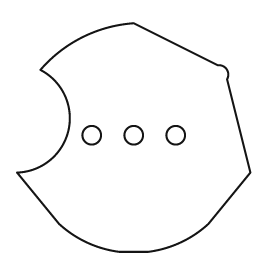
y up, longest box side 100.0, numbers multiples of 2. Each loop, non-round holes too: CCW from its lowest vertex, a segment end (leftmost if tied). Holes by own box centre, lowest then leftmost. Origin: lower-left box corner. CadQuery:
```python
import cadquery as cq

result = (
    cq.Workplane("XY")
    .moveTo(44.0, 0.0)
    .lineTo(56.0, 0.0)
    .threePointArc((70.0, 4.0), (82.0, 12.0))
    .lineTo(100.0, 34.0)
    .lineTo(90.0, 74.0)
    .threePointArc((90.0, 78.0), (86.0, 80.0))
    .lineTo(50.0, 98.0)
    .threePointArc((28.0, 92.0), (10.0, 78.0))
    .threePointArc((22.0, 52.0), (0.0, 34.0))
    .lineTo(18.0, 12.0)
    .threePointArc((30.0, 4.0), (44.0, 0.0))
    .close()
    .moveTo(32.0, 50.0)
    .circle(4.0)
    .moveTo(50.0, 50.0)
    .circle(4.0)
    .moveTo(68.0, 50.0)
    .circle(4.0)
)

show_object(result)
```